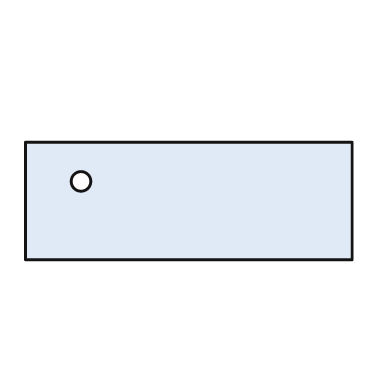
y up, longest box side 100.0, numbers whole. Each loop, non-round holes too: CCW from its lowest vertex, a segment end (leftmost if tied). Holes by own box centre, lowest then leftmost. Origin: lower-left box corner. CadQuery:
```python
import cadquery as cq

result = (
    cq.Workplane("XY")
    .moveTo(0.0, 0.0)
    .lineTo(100.0, 0.0)
    .lineTo(100.0, 36.0)
    .lineTo(0.0, 36.0)
    .close()
    .moveTo(17.0, 24.0)
    .circle(3.0)
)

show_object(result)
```